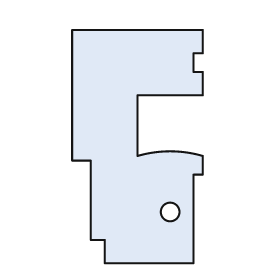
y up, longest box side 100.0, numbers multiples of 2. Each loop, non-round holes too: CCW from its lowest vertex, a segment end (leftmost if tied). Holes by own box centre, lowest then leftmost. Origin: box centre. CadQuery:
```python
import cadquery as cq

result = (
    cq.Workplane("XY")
    .moveTo(-14.0, -50.0)
    .lineTo(24.0, -50.0)
    .lineTo(24.0, -12.0)
    .lineTo(28.0, -12.0)
    .lineTo(28.0, -4.0)
    .threePointArc((14.0, -2.0), (0.0, -4.0))
    .lineTo(0.0, 22.0)
    .lineTo(28.0, 22.0)
    .lineTo(28.0, 32.0)
    .lineTo(24.0, 32.0)
    .lineTo(24.0, 40.0)
    .lineTo(28.0, 40.0)
    .lineTo(28.0, 50.0)
    .lineTo(-28.0, 50.0)
    .lineTo(-28.0, -6.0)
    .lineTo(-20.0, -6.0)
    .lineTo(-20.0, -40.0)
    .lineTo(-14.0, -40.0)
    .close()
    .moveTo(14.0, -28.0)
    .circle(4.0)
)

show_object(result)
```